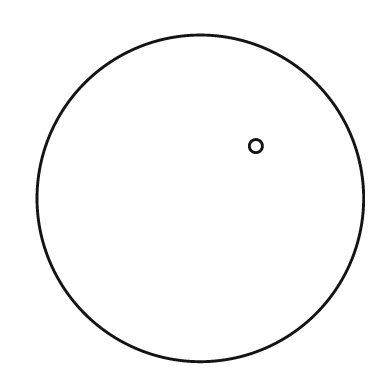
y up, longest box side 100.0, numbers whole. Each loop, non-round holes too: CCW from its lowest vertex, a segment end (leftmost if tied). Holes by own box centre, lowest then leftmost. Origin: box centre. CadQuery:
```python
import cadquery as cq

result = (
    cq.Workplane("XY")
    .moveTo(0.0, 0.0)
    .circle(50.0)
    .moveTo(17.0, 16.0)
    .circle(2.0)
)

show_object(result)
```